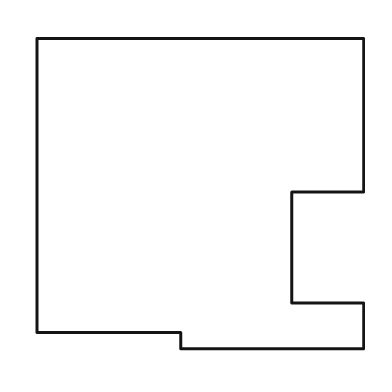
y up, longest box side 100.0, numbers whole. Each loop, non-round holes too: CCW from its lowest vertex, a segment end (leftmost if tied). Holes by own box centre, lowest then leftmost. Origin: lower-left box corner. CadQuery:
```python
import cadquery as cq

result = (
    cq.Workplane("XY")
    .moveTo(44.0, 0.0)
    .lineTo(100.0, 0.0)
    .lineTo(100.0, 14.0)
    .lineTo(78.0, 14.0)
    .lineTo(78.0, 48.0)
    .lineTo(100.0, 48.0)
    .lineTo(100.0, 95.0)
    .lineTo(0.0, 95.0)
    .lineTo(0.0, 5.0)
    .lineTo(44.0, 5.0)
    .close()
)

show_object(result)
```